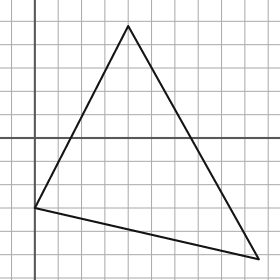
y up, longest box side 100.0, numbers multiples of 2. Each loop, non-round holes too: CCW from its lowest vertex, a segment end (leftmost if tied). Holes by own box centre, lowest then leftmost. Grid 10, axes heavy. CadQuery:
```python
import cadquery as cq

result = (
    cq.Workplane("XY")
    .moveTo(96.0, -52.0)
    .lineTo(40.0, 48.0)
    .lineTo(0.0, -30.0)
    .close()
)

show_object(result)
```